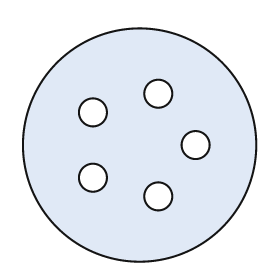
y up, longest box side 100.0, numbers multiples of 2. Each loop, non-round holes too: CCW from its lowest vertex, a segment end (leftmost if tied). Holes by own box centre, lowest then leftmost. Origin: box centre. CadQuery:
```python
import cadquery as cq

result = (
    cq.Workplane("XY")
    .moveTo(0.0, 0.0)
    .circle(50.0)
    .moveTo(8.0, -22.0)
    .circle(6.0)
    .moveTo(-20.0, -14.0)
    .circle(6.0)
    .moveTo(24.0, 0.0)
    .circle(6.0)
    .moveTo(-20.0, 14.0)
    .circle(6.0)
    .moveTo(8.0, 22.0)
    .circle(6.0)
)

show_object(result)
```